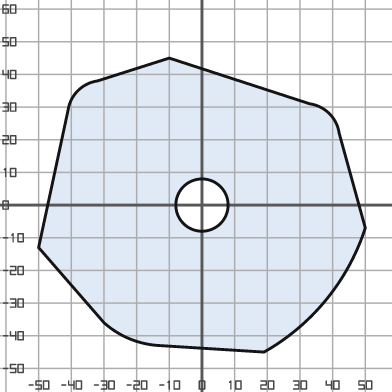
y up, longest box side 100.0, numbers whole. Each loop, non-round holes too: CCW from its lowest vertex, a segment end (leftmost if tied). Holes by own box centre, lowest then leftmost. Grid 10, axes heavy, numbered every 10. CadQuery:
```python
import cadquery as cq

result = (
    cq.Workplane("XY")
    .moveTo(19.0, -45.0)
    .threePointArc((38.0, -29.0), (50.0, -7.0))
    .lineTo(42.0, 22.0)
    .threePointArc((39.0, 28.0), (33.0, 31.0))
    .lineTo(-10.0, 45.0)
    .lineTo(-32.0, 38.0)
    .threePointArc((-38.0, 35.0), (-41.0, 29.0))
    .lineTo(-50.0, -13.0)
    .lineTo(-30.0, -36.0)
    .threePointArc((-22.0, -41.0), (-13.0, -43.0))
    .close()
    .moveTo(0.0, 0.0)
    .circle(8.0)
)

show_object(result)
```